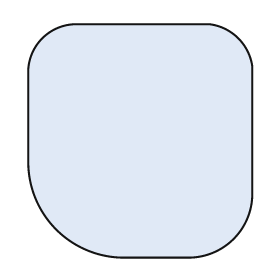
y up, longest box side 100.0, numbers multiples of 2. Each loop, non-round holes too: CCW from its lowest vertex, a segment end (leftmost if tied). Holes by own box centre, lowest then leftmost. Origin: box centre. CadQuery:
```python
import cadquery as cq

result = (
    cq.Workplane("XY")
    .moveTo(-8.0, -50.0)
    .lineTo(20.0, -50.0)
    .threePointArc((40.0, -42.0), (48.0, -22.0))
    .lineTo(48.0, 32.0)
    .threePointArc((42.0, 44.0), (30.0, 50.0))
    .lineTo(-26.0, 50.0)
    .threePointArc((-42.0, 44.0), (-48.0, 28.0))
    .lineTo(-48.0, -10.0)
    .threePointArc((-36.0, -38.0), (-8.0, -50.0))
    .close()
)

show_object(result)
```